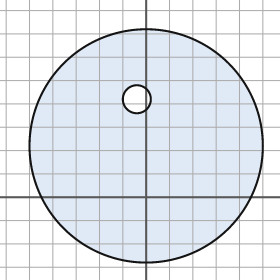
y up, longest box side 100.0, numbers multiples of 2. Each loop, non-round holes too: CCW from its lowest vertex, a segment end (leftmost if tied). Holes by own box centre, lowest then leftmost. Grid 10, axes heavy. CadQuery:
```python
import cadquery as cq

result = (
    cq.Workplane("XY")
    .moveTo(0.0, 22.0)
    .circle(50.0)
    .moveTo(-4.0, 42.0)
    .circle(6.0)
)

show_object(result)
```